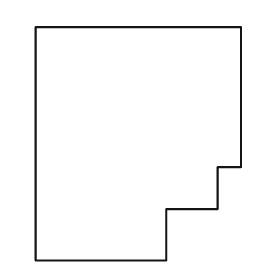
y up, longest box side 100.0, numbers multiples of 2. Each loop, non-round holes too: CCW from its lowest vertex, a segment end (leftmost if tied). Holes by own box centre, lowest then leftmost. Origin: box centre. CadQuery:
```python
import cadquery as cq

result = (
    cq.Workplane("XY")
    .moveTo(-44.0, -50.0)
    .lineTo(12.0, -50.0)
    .lineTo(12.0, -28.0)
    .lineTo(34.0, -28.0)
    .lineTo(34.0, -10.0)
    .lineTo(44.0, -10.0)
    .lineTo(44.0, 50.0)
    .lineTo(-44.0, 50.0)
    .close()
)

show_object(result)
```